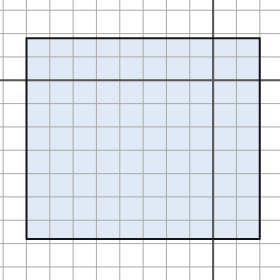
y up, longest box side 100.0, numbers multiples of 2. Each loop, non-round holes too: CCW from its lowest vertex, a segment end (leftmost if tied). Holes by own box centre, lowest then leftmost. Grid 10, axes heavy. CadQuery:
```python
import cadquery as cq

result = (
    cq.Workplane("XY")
    .moveTo(-80.0, -68.0)
    .lineTo(20.0, -68.0)
    .lineTo(20.0, 18.0)
    .lineTo(-80.0, 18.0)
    .close()
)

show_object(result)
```